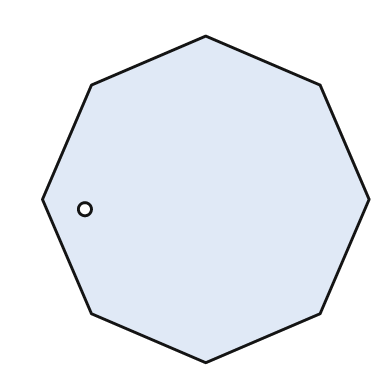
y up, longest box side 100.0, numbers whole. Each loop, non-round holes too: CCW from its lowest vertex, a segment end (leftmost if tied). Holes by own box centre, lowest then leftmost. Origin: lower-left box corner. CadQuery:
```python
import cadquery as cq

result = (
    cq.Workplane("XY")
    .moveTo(50.0, 0.0)
    .lineTo(85.0, 15.0)
    .lineTo(100.0, 50.0)
    .lineTo(85.0, 85.0)
    .lineTo(50.0, 100.0)
    .lineTo(15.0, 85.0)
    .lineTo(0.0, 50.0)
    .lineTo(15.0, 15.0)
    .close()
    .moveTo(13.0, 47.0)
    .circle(2.0)
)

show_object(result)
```